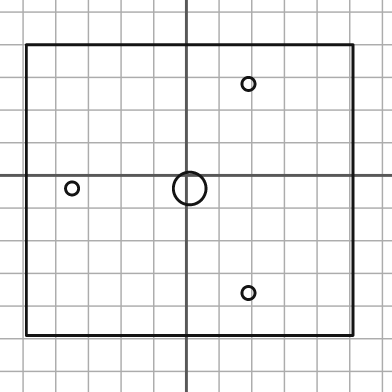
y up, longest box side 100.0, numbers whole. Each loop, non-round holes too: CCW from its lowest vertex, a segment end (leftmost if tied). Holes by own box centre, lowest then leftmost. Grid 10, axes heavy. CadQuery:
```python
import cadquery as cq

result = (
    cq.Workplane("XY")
    .moveTo(-49.0, -49.0)
    .lineTo(51.0, -49.0)
    .lineTo(51.0, 40.0)
    .lineTo(-49.0, 40.0)
    .close()
    .moveTo(19.0, -36.0)
    .circle(2.0)
    .moveTo(-35.0, -4.0)
    .circle(2.0)
    .moveTo(1.0, -4.0)
    .circle(5.0)
    .moveTo(19.0, 28.0)
    .circle(2.0)
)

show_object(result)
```